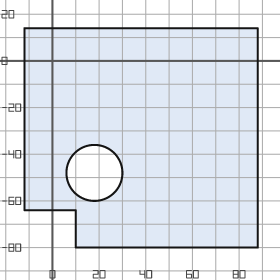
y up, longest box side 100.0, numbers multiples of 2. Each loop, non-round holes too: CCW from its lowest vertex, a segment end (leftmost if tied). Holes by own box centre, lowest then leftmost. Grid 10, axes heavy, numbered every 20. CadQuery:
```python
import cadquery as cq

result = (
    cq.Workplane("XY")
    .moveTo(10.0, -80.0)
    .lineTo(88.0, -80.0)
    .lineTo(88.0, 14.0)
    .lineTo(-12.0, 14.0)
    .lineTo(-12.0, -64.0)
    .lineTo(10.0, -64.0)
    .close()
    .moveTo(18.0, -48.0)
    .circle(12.0)
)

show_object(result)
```